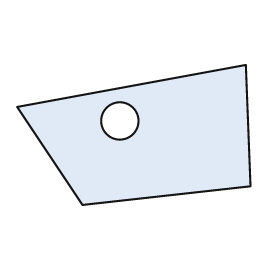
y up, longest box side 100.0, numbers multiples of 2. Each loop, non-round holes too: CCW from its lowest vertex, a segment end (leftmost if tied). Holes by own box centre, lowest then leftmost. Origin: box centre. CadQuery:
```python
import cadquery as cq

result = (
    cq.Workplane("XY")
    .moveTo(-22.0, -30.0)
    .lineTo(50.0, -22.0)
    .lineTo(48.0, 30.0)
    .lineTo(-50.0, 12.0)
    .close()
    .moveTo(-6.0, 6.0)
    .circle(8.0)
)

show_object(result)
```